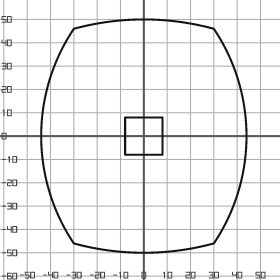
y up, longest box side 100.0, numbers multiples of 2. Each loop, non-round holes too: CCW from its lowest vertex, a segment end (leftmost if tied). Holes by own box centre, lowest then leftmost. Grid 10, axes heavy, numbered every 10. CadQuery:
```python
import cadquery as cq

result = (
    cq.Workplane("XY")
    .moveTo(-30.0, -46.0)
    .threePointArc((0.0, -50.0), (30.0, -46.0))
    .threePointArc((44.0, 0.0), (30.0, 46.0))
    .threePointArc((0.0, 50.0), (-30.0, 46.0))
    .threePointArc((-44.0, 0.0), (-30.0, -46.0))
    .close()
    .moveTo(-8.0, -8.0)
    .lineTo(8.0, -8.0)
    .lineTo(8.0, 8.0)
    .lineTo(-8.0, 8.0)
    .close()
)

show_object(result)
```